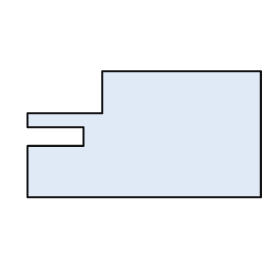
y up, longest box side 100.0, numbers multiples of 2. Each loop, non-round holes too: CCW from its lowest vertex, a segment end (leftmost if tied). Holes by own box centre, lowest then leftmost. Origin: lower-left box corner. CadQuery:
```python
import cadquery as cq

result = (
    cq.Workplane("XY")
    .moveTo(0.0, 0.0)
    .lineTo(100.0, 0.0)
    .lineTo(100.0, 54.0)
    .lineTo(32.0, 54.0)
    .lineTo(32.0, 36.0)
    .lineTo(0.0, 36.0)
    .lineTo(0.0, 30.0)
    .lineTo(24.0, 30.0)
    .lineTo(24.0, 22.0)
    .lineTo(0.0, 22.0)
    .close()
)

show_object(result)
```